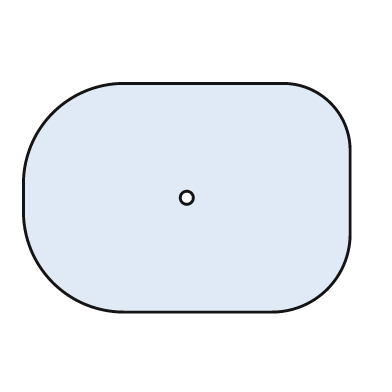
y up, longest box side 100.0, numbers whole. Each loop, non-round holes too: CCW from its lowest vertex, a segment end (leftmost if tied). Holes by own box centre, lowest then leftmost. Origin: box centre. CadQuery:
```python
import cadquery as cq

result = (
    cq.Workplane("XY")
    .moveTo(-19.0, -35.0)
    .lineTo(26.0, -35.0)
    .threePointArc((43.0, -28.0), (50.0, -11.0))
    .lineTo(50.0, 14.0)
    .threePointArc((44.0, 29.0), (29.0, 35.0))
    .lineTo(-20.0, 35.0)
    .threePointArc((-41.0, 26.0), (-50.0, 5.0))
    .lineTo(-50.0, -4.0)
    .threePointArc((-41.0, -26.0), (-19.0, -35.0))
    .close()
    .moveTo(0.0, 0.0)
    .circle(2.0)
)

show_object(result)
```